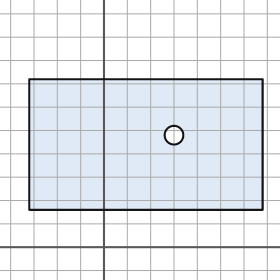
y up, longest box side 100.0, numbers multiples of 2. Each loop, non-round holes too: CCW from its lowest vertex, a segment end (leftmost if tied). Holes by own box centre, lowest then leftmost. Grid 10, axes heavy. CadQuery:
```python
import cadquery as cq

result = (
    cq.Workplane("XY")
    .moveTo(-32.0, 16.0)
    .lineTo(68.0, 16.0)
    .lineTo(68.0, 72.0)
    .lineTo(-32.0, 72.0)
    .close()
    .moveTo(30.0, 48.0)
    .circle(4.0)
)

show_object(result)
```